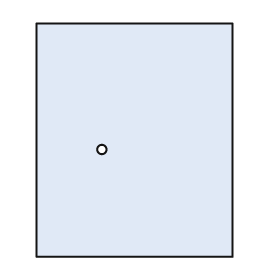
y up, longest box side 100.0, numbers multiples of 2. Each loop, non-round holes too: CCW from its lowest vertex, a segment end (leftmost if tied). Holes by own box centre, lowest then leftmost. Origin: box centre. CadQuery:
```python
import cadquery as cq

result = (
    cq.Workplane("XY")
    .moveTo(-42.0, -50.0)
    .lineTo(42.0, -50.0)
    .lineTo(42.0, 50.0)
    .lineTo(-42.0, 50.0)
    .close()
    .moveTo(-14.0, -4.0)
    .circle(2.0)
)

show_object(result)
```